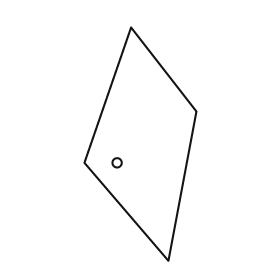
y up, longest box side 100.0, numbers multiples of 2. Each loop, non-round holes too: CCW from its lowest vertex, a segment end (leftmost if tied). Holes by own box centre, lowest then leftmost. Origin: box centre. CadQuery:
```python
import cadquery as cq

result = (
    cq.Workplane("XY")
    .moveTo(12.0, -50.0)
    .lineTo(24.0, 14.0)
    .lineTo(-4.0, 50.0)
    .lineTo(-24.0, -8.0)
    .close()
    .moveTo(-10.0, -8.0)
    .circle(2.0)
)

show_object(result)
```